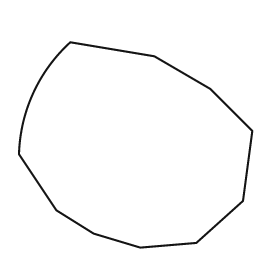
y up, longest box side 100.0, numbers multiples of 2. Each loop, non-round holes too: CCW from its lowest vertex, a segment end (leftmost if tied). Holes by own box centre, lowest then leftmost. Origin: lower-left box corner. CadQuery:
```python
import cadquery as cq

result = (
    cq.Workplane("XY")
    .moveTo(52.0, 0.0)
    .lineTo(76.0, 2.0)
    .lineTo(96.0, 20.0)
    .lineTo(100.0, 50.0)
    .lineTo(82.0, 68.0)
    .lineTo(58.0, 82.0)
    .lineTo(22.0, 88.0)
    .threePointArc((6.0, 66.0), (0.0, 40.0))
    .lineTo(16.0, 16.0)
    .lineTo(32.0, 6.0)
    .close()
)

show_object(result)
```